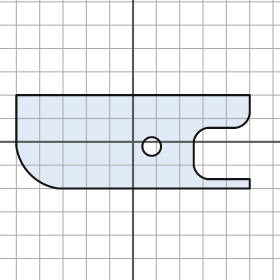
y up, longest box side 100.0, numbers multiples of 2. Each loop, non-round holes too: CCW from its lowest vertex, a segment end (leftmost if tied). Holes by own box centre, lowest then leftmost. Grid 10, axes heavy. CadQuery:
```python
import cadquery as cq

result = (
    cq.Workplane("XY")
    .moveTo(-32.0, -20.0)
    .lineTo(50.0, -20.0)
    .lineTo(50.0, -16.0)
    .lineTo(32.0, -16.0)
    .threePointArc((28.0, -14.0), (26.0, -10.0))
    .lineTo(26.0, 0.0)
    .threePointArc((28.0, 4.0), (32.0, 6.0))
    .lineTo(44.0, 6.0)
    .threePointArc((48.0, 8.0), (50.0, 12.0))
    .lineTo(50.0, 20.0)
    .lineTo(-50.0, 20.0)
    .lineTo(-50.0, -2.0)
    .threePointArc((-44.0, -14.0), (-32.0, -20.0))
    .close()
    .moveTo(8.0, -2.0)
    .circle(4.0)
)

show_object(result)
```